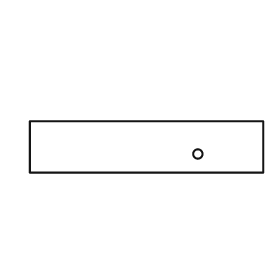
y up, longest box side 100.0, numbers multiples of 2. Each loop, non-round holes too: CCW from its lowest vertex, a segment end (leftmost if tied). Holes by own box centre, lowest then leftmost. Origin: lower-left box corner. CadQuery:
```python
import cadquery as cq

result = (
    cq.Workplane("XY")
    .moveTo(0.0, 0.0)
    .lineTo(100.0, 0.0)
    .lineTo(100.0, 22.0)
    .lineTo(0.0, 22.0)
    .close()
    .moveTo(72.0, 8.0)
    .circle(2.0)
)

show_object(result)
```